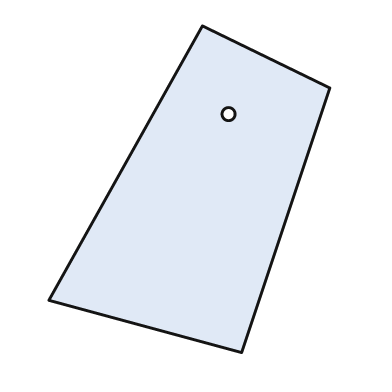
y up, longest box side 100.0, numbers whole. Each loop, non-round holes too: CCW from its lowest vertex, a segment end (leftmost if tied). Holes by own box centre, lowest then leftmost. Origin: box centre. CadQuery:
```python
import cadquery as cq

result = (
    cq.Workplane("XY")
    .moveTo(16.0, -50.0)
    .lineTo(43.0, 31.0)
    .lineTo(4.0, 50.0)
    .lineTo(-43.0, -34.0)
    .close()
    .moveTo(12.0, 23.0)
    .circle(2.0)
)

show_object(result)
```